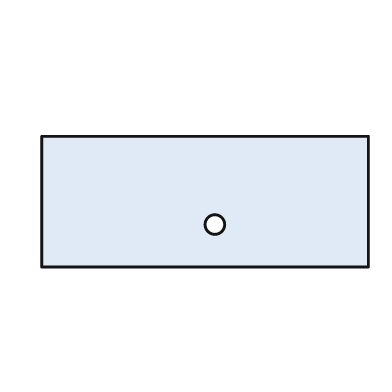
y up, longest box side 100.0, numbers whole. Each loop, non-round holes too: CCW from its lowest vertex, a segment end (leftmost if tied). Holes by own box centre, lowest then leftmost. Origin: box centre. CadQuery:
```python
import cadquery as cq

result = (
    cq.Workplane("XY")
    .moveTo(-50.0, -20.0)
    .lineTo(50.0, -20.0)
    .lineTo(50.0, 20.0)
    .lineTo(-50.0, 20.0)
    .close()
    .moveTo(3.0, -7.0)
    .circle(3.0)
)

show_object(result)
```